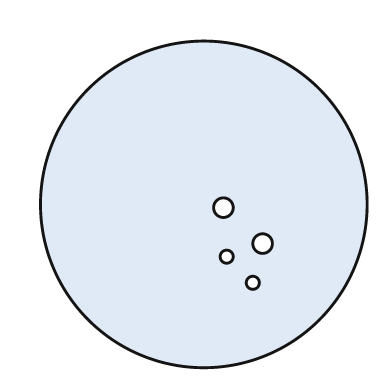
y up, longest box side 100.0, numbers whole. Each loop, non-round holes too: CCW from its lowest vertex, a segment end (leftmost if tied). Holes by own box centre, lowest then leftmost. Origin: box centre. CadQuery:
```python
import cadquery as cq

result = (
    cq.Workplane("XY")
    .moveTo(0.0, 0.0)
    .circle(50.0)
    .moveTo(15.0, -24.0)
    .circle(2.0)
    .moveTo(7.0, -16.0)
    .circle(2.0)
    .moveTo(18.0, -12.0)
    .circle(3.0)
    .moveTo(6.0, -1.0)
    .circle(3.0)
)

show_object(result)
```